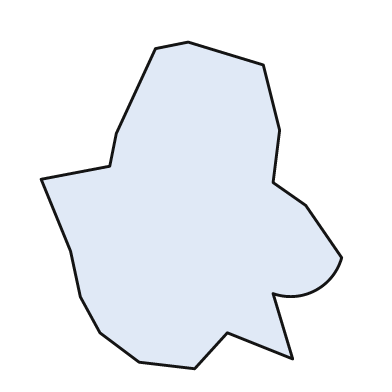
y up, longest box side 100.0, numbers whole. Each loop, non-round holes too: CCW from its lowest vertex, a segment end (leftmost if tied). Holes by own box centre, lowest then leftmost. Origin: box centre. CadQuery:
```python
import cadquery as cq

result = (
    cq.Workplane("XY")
    .moveTo(1.0, -50.0)
    .lineTo(11.0, -39.0)
    .lineTo(31.0, -47.0)
    .lineTo(25.0, -27.0)
    .threePointArc((38.0, -26.0), (46.0, -16.0))
    .lineTo(35.0, 0.0)
    .lineTo(25.0, 7.0)
    .lineTo(27.0, 23.0)
    .lineTo(22.0, 43.0)
    .lineTo(-1.0, 50.0)
    .lineTo(-11.0, 48.0)
    .lineTo(-23.0, 22.0)
    .lineTo(-25.0, 12.0)
    .lineTo(-46.0, 8.0)
    .lineTo(-37.0, -14.0)
    .lineTo(-34.0, -28.0)
    .lineTo(-28.0, -39.0)
    .lineTo(-16.0, -48.0)
    .close()
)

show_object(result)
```